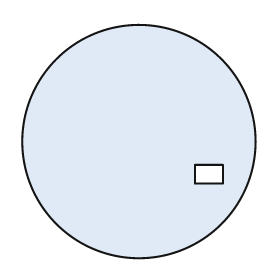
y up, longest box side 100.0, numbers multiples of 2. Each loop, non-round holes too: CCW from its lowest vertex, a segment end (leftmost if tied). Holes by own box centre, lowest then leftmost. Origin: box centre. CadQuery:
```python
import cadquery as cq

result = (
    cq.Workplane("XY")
    .moveTo(0.0, 0.0)
    .circle(50.0)
    .moveTo(24.0, -18.0)
    .lineTo(36.0, -18.0)
    .lineTo(36.0, -10.0)
    .lineTo(24.0, -10.0)
    .close()
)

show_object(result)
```